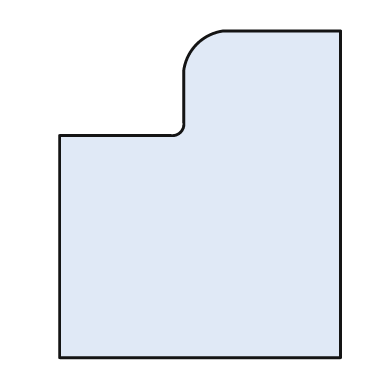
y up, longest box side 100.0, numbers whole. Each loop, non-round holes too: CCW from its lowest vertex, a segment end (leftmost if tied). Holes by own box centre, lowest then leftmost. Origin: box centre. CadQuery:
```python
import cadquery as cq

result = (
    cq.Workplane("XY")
    .moveTo(-43.0, -50.0)
    .lineTo(43.0, -50.0)
    .lineTo(43.0, 50.0)
    .lineTo(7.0, 50.0)
    .threePointArc((-1.0, 46.0), (-5.0, 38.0))
    .lineTo(-5.0, 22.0)
    .threePointArc((-6.0, 19.0), (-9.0, 18.0))
    .lineTo(-43.0, 18.0)
    .close()
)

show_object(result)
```